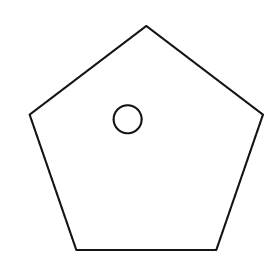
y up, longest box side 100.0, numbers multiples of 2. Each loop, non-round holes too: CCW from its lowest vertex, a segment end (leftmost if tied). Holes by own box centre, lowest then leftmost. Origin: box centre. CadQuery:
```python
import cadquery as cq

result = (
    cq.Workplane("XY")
    .moveTo(-30.0, -48.0)
    .lineTo(30.0, -48.0)
    .lineTo(50.0, 10.0)
    .lineTo(0.0, 48.0)
    .lineTo(-50.0, 10.0)
    .close()
    .moveTo(-8.0, 8.0)
    .circle(6.0)
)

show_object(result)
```